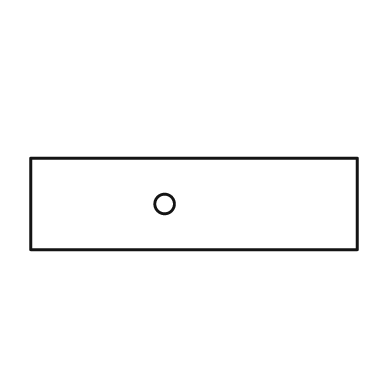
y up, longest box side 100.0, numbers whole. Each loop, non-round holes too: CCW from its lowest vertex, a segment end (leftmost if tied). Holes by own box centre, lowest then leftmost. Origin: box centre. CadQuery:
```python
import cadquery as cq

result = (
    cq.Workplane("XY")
    .moveTo(-50.0, -14.0)
    .lineTo(50.0, -14.0)
    .lineTo(50.0, 14.0)
    .lineTo(-50.0, 14.0)
    .close()
    .moveTo(-9.0, 0.0)
    .circle(3.0)
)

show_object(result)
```